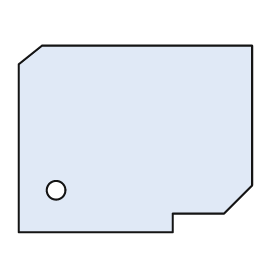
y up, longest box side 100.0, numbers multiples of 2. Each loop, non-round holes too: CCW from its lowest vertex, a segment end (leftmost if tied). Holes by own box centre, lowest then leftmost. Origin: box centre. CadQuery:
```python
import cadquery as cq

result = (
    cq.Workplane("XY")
    .moveTo(-50.0, -40.0)
    .lineTo(16.0, -40.0)
    .lineTo(16.0, -32.0)
    .lineTo(38.0, -32.0)
    .lineTo(50.0, -20.0)
    .lineTo(50.0, 40.0)
    .lineTo(-40.0, 40.0)
    .lineTo(-50.0, 32.0)
    .close()
    .moveTo(-34.0, -22.0)
    .circle(4.0)
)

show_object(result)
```